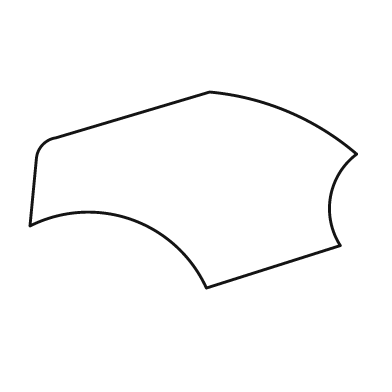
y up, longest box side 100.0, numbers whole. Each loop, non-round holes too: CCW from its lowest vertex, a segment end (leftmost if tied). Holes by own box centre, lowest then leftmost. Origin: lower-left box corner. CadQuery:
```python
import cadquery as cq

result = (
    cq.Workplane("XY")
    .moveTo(54.0, 0.0)
    .lineTo(95.0, 13.0)
    .threePointArc((92.0, 28.0), (100.0, 41.0))
    .threePointArc((79.0, 54.0), (55.0, 60.0))
    .lineTo(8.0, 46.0)
    .threePointArc((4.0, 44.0), (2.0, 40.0))
    .lineTo(0.0, 19.0)
    .threePointArc((31.0, 21.0), (54.0, 0.0))
    .close()
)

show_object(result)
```